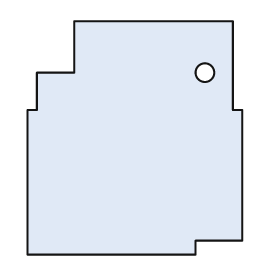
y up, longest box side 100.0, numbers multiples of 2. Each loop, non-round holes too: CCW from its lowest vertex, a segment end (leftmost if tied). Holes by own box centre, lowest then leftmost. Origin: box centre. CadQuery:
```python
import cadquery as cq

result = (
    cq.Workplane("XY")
    .moveTo(-46.0, -50.0)
    .lineTo(26.0, -50.0)
    .lineTo(26.0, -44.0)
    .lineTo(46.0, -44.0)
    .lineTo(46.0, 12.0)
    .lineTo(42.0, 12.0)
    .lineTo(42.0, 50.0)
    .lineTo(-26.0, 50.0)
    .lineTo(-26.0, 28.0)
    .lineTo(-42.0, 28.0)
    .lineTo(-42.0, 12.0)
    .lineTo(-46.0, 12.0)
    .close()
    .moveTo(30.0, 28.0)
    .circle(4.0)
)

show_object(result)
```